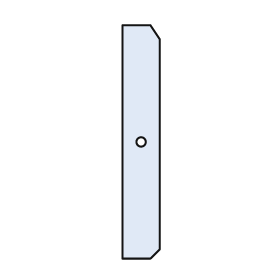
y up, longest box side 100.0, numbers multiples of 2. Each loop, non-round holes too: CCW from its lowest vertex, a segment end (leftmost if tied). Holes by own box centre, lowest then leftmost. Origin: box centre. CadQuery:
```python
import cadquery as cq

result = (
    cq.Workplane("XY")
    .moveTo(-8.0, -50.0)
    .lineTo(4.0, -50.0)
    .lineTo(8.0, -46.0)
    .lineTo(8.0, 44.0)
    .lineTo(4.0, 50.0)
    .lineTo(-8.0, 50.0)
    .close()
    .moveTo(0.0, 0.0)
    .circle(2.0)
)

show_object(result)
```